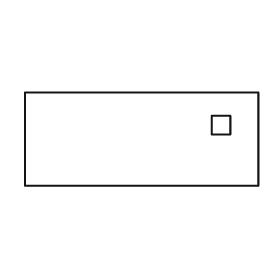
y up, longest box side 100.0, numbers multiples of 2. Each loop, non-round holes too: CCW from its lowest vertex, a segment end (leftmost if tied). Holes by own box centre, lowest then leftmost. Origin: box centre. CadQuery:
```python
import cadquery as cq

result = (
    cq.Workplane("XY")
    .moveTo(-50.0, -20.0)
    .lineTo(50.0, -20.0)
    .lineTo(50.0, 20.0)
    .lineTo(-50.0, 20.0)
    .close()
    .moveTo(30.0, 2.0)
    .lineTo(38.0, 2.0)
    .lineTo(38.0, 10.0)
    .lineTo(30.0, 10.0)
    .close()
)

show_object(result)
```